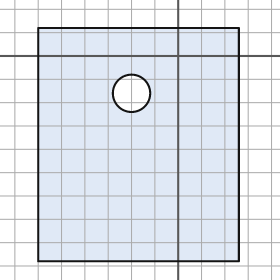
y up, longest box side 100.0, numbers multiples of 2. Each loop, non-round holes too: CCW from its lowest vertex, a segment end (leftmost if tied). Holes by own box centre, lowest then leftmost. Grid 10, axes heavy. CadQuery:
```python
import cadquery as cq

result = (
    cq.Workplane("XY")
    .moveTo(-60.0, -88.0)
    .lineTo(26.0, -88.0)
    .lineTo(26.0, 12.0)
    .lineTo(-60.0, 12.0)
    .close()
    .moveTo(-20.0, -16.0)
    .circle(8.0)
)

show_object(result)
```